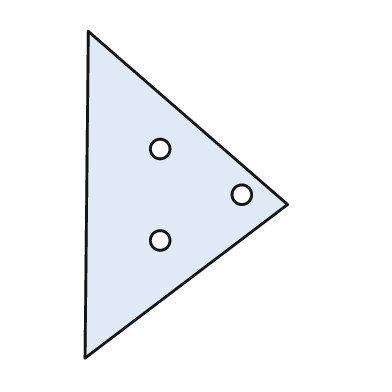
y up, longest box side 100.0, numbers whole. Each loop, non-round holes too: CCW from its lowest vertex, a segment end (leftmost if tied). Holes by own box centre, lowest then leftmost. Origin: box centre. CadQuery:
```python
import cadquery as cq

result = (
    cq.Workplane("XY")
    .moveTo(-31.0, -50.0)
    .lineTo(31.0, -3.0)
    .lineTo(-30.0, 50.0)
    .close()
    .moveTo(-8.0, -14.0)
    .circle(3.0)
    .moveTo(17.0, 0.0)
    .circle(3.0)
    .moveTo(-8.0, 14.0)
    .circle(3.0)
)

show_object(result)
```